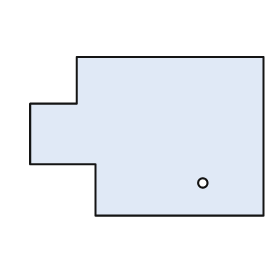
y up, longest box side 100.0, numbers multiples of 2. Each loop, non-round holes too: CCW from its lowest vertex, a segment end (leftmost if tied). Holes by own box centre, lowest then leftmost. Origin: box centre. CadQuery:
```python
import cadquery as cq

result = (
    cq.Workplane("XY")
    .moveTo(-22.0, -34.0)
    .lineTo(50.0, -34.0)
    .lineTo(50.0, 34.0)
    .lineTo(-30.0, 34.0)
    .lineTo(-30.0, 14.0)
    .lineTo(-50.0, 14.0)
    .lineTo(-50.0, -12.0)
    .lineTo(-22.0, -12.0)
    .close()
    .moveTo(24.0, -20.0)
    .circle(2.0)
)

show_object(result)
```